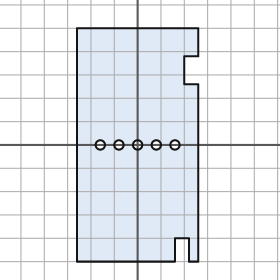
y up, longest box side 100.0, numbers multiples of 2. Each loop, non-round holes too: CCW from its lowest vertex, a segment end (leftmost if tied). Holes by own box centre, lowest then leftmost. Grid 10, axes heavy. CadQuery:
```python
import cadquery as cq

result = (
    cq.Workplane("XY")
    .moveTo(-26.0, -50.0)
    .lineTo(16.0, -50.0)
    .lineTo(16.0, -40.0)
    .lineTo(22.0, -40.0)
    .lineTo(22.0, -50.0)
    .lineTo(26.0, -50.0)
    .lineTo(26.0, 26.0)
    .lineTo(20.0, 26.0)
    .lineTo(20.0, 38.0)
    .lineTo(26.0, 38.0)
    .lineTo(26.0, 50.0)
    .lineTo(-26.0, 50.0)
    .close()
    .moveTo(-16.0, 0.0)
    .circle(2.0)
    .moveTo(-8.0, 0.0)
    .circle(2.0)
    .moveTo(0.0, 0.0)
    .circle(2.0)
    .moveTo(8.0, 0.0)
    .circle(2.0)
    .moveTo(16.0, 0.0)
    .circle(2.0)
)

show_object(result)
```